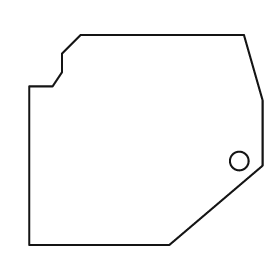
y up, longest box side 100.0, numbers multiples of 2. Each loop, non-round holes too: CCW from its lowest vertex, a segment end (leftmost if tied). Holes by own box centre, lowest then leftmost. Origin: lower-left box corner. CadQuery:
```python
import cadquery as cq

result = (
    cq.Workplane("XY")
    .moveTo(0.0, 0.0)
    .lineTo(60.0, 0.0)
    .lineTo(100.0, 34.0)
    .lineTo(100.0, 62.0)
    .lineTo(92.0, 90.0)
    .lineTo(22.0, 90.0)
    .lineTo(14.0, 82.0)
    .lineTo(14.0, 74.0)
    .lineTo(10.0, 68.0)
    .lineTo(0.0, 68.0)
    .close()
    .moveTo(90.0, 36.0)
    .circle(4.0)
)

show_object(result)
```